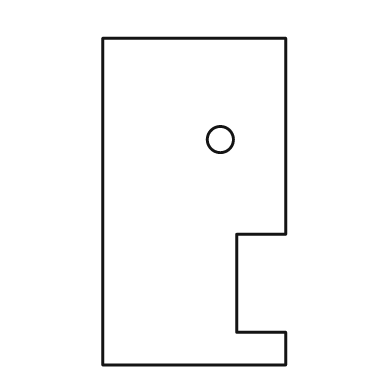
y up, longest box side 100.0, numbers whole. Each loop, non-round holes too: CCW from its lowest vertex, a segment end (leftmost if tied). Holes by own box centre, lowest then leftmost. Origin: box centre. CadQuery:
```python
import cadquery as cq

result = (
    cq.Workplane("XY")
    .moveTo(-28.0, -50.0)
    .lineTo(28.0, -50.0)
    .lineTo(28.0, -40.0)
    .lineTo(13.0, -40.0)
    .lineTo(13.0, -10.0)
    .lineTo(28.0, -10.0)
    .lineTo(28.0, 50.0)
    .lineTo(-28.0, 50.0)
    .close()
    .moveTo(8.0, 19.0)
    .circle(4.0)
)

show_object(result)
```